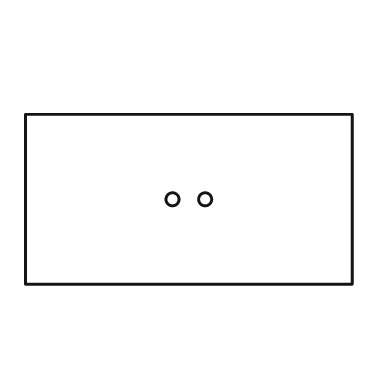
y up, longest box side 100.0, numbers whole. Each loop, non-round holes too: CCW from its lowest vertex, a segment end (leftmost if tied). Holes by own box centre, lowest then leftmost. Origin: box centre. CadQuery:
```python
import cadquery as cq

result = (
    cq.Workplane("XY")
    .moveTo(-50.0, -26.0)
    .lineTo(50.0, -26.0)
    .lineTo(50.0, 26.0)
    .lineTo(-50.0, 26.0)
    .close()
    .moveTo(-5.0, 0.0)
    .circle(2.0)
    .moveTo(5.0, 0.0)
    .circle(2.0)
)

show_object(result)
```